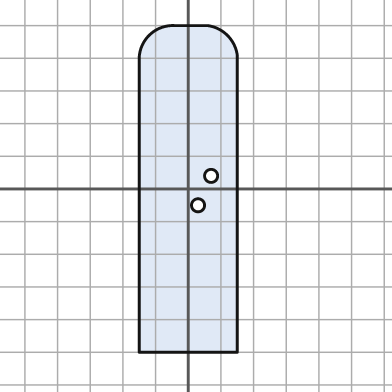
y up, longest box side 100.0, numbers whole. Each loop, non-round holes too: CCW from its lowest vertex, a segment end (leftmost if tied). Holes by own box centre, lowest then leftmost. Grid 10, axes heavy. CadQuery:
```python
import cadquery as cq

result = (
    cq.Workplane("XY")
    .moveTo(-15.0, -50.0)
    .lineTo(15.0, -50.0)
    .lineTo(15.0, 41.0)
    .threePointArc((12.0, 47.0), (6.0, 50.0))
    .lineTo(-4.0, 50.0)
    .threePointArc((-12.0, 47.0), (-15.0, 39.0))
    .close()
    .moveTo(3.0, -5.0)
    .circle(2.0)
    .moveTo(7.0, 4.0)
    .circle(2.0)
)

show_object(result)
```